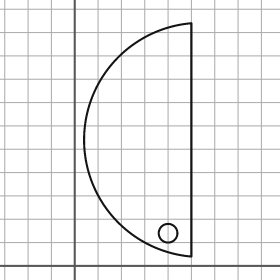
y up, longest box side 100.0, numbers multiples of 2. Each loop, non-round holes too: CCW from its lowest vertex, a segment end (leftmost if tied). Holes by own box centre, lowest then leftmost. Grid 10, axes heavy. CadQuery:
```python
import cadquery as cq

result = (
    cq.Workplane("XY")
    .moveTo(50.0, 4.0)
    .lineTo(50.0, 104.0)
    .threePointArc((4.0, 54.0), (50.0, 4.0))
    .close()
    .moveTo(40.0, 14.0)
    .circle(4.0)
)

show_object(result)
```